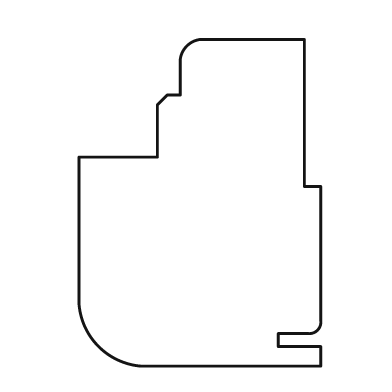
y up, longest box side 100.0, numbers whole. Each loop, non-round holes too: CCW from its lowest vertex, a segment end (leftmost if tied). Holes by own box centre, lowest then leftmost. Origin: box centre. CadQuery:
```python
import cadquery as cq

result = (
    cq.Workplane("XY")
    .moveTo(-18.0, -50.0)
    .lineTo(37.0, -50.0)
    .lineTo(37.0, -44.0)
    .lineTo(24.0, -44.0)
    .lineTo(24.0, -40.0)
    .lineTo(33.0, -40.0)
    .threePointArc((36.0, -39.0), (37.0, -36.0))
    .lineTo(37.0, 5.0)
    .lineTo(32.0, 5.0)
    .lineTo(32.0, 50.0)
    .lineTo(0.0, 50.0)
    .threePointArc((-4.0, 48.0), (-6.0, 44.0))
    .lineTo(-6.0, 33.0)
    .lineTo(-10.0, 33.0)
    .lineTo(-13.0, 30.0)
    .lineTo(-13.0, 14.0)
    .lineTo(-37.0, 14.0)
    .lineTo(-37.0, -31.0)
    .threePointArc((-31.0, -44.0), (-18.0, -50.0))
    .close()
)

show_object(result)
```